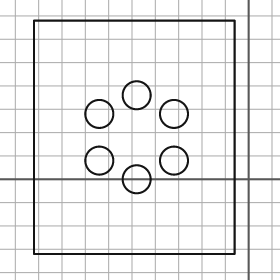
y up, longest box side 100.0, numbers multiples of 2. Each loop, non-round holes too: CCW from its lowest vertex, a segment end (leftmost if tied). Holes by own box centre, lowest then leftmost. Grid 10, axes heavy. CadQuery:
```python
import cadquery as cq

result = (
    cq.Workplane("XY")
    .moveTo(-92.0, -32.0)
    .lineTo(-6.0, -32.0)
    .lineTo(-6.0, 68.0)
    .lineTo(-92.0, 68.0)
    .close()
    .moveTo(-48.0, 0.0)
    .circle(6.0)
    .moveTo(-64.0, 8.0)
    .circle(6.0)
    .moveTo(-32.0, 8.0)
    .circle(6.0)
    .moveTo(-64.0, 28.0)
    .circle(6.0)
    .moveTo(-32.0, 28.0)
    .circle(6.0)
    .moveTo(-48.0, 36.0)
    .circle(6.0)
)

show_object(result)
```